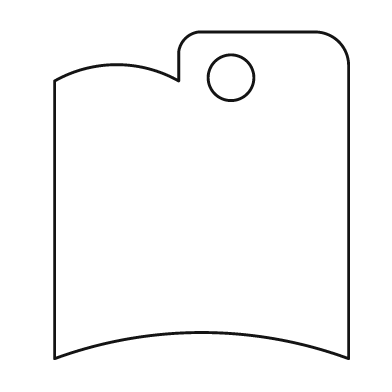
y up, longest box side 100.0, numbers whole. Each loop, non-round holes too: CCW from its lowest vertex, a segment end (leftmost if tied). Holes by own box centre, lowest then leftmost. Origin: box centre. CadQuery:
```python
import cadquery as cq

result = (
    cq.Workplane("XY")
    .moveTo(-45.0, -50.0)
    .threePointArc((0.0, -42.0), (45.0, -50.0))
    .lineTo(45.0, 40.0)
    .threePointArc((42.0, 47.0), (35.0, 50.0))
    .lineTo(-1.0, 50.0)
    .threePointArc((-5.0, 48.0), (-7.0, 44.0))
    .lineTo(-7.0, 35.0)
    .threePointArc((-26.0, 40.0), (-45.0, 35.0))
    .close()
    .moveTo(9.0, 36.0)
    .circle(7.0)
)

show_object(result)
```